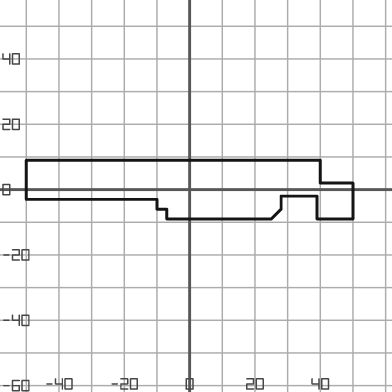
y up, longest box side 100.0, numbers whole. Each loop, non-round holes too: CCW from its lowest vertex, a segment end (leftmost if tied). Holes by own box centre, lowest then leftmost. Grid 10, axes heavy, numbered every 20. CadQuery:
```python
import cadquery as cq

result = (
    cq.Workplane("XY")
    .moveTo(-7.0, -9.0)
    .lineTo(25.0, -9.0)
    .lineTo(28.0, -6.0)
    .lineTo(28.0, -2.0)
    .lineTo(39.0, -2.0)
    .lineTo(39.0, -9.0)
    .lineTo(50.0, -9.0)
    .lineTo(50.0, 2.0)
    .lineTo(40.0, 2.0)
    .lineTo(40.0, 9.0)
    .lineTo(-50.0, 9.0)
    .lineTo(-50.0, -3.0)
    .lineTo(-10.0, -3.0)
    .lineTo(-10.0, -6.0)
    .lineTo(-7.0, -6.0)
    .close()
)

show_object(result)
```